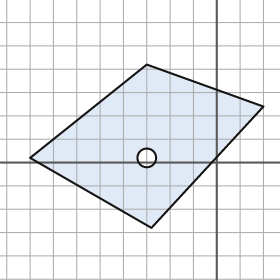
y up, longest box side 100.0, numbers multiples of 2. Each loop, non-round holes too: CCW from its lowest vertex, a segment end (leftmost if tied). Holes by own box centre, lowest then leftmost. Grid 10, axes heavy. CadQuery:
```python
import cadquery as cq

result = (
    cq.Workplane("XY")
    .moveTo(-28.0, -28.0)
    .lineTo(20.0, 24.0)
    .lineTo(-30.0, 42.0)
    .lineTo(-80.0, 2.0)
    .close()
    .moveTo(-30.0, 2.0)
    .circle(4.0)
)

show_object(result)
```